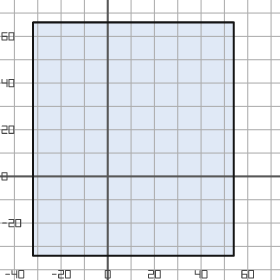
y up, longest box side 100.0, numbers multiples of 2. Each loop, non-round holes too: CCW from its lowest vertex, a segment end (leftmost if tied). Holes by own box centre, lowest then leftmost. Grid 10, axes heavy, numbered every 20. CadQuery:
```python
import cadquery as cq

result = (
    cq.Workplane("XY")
    .moveTo(-32.0, -34.0)
    .lineTo(54.0, -34.0)
    .lineTo(54.0, 66.0)
    .lineTo(-32.0, 66.0)
    .close()
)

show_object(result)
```